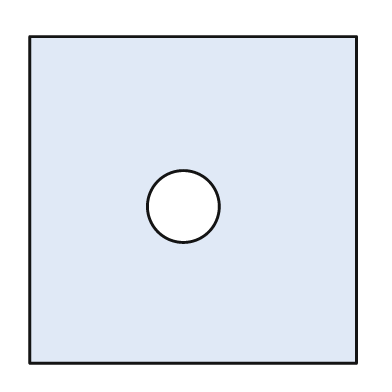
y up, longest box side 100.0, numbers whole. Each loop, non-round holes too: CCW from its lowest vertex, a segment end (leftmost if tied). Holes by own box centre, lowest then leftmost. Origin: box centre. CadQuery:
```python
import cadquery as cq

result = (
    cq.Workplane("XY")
    .moveTo(-50.0, -50.0)
    .lineTo(50.0, -50.0)
    .lineTo(50.0, 50.0)
    .lineTo(-50.0, 50.0)
    .close()
    .moveTo(-3.0, -2.0)
    .circle(11.0)
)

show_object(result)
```